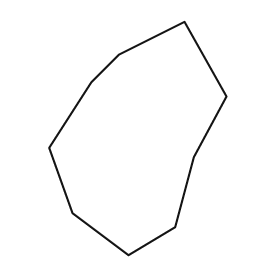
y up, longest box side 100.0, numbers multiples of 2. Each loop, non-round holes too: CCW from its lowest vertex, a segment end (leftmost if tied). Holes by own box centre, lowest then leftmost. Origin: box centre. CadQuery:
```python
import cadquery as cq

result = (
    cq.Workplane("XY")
    .moveTo(-4.0, -50.0)
    .lineTo(16.0, -38.0)
    .lineTo(24.0, -8.0)
    .lineTo(38.0, 18.0)
    .lineTo(20.0, 50.0)
    .lineTo(-8.0, 36.0)
    .lineTo(-20.0, 24.0)
    .lineTo(-38.0, -4.0)
    .lineTo(-28.0, -32.0)
    .close()
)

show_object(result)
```